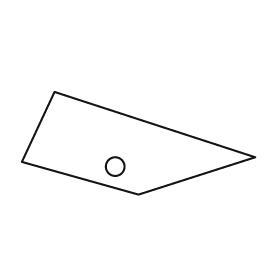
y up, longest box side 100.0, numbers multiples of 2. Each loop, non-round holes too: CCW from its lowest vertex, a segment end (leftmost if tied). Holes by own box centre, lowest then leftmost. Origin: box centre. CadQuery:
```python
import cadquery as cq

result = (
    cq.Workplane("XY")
    .moveTo(0.0, -22.0)
    .lineTo(50.0, -6.0)
    .lineTo(-36.0, 22.0)
    .lineTo(-50.0, -8.0)
    .close()
    .moveTo(-10.0, -10.0)
    .circle(4.0)
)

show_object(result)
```